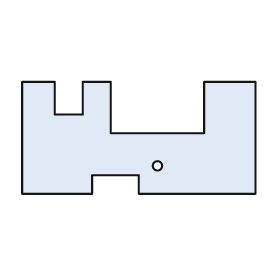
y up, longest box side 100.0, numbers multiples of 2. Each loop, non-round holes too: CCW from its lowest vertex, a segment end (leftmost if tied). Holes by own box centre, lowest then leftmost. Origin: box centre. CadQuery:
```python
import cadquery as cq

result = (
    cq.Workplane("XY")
    .moveTo(-50.0, -24.0)
    .lineTo(-20.0, -24.0)
    .lineTo(-20.0, -16.0)
    .lineTo(0.0, -16.0)
    .lineTo(0.0, -24.0)
    .lineTo(50.0, -24.0)
    .lineTo(50.0, 24.0)
    .lineTo(28.0, 24.0)
    .lineTo(28.0, 2.0)
    .lineTo(-12.0, 2.0)
    .lineTo(-12.0, 24.0)
    .lineTo(-24.0, 24.0)
    .lineTo(-24.0, 10.0)
    .lineTo(-36.0, 10.0)
    .lineTo(-36.0, 24.0)
    .lineTo(-50.0, 24.0)
    .close()
    .moveTo(8.0, -12.0)
    .circle(2.0)
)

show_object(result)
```